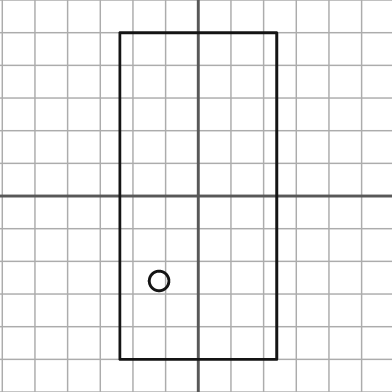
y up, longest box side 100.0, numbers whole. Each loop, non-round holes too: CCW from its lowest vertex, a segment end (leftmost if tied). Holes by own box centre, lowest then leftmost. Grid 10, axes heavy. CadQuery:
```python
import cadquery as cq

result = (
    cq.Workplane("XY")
    .moveTo(-24.0, -50.0)
    .lineTo(24.0, -50.0)
    .lineTo(24.0, 50.0)
    .lineTo(-24.0, 50.0)
    .close()
    .moveTo(-12.0, -26.0)
    .circle(3.0)
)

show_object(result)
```